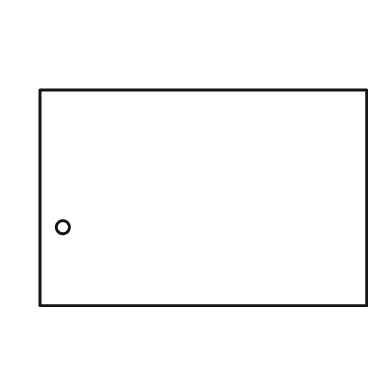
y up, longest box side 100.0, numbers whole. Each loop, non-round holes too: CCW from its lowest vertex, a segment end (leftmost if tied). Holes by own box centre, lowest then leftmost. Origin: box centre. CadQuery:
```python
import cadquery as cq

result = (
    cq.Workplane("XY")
    .moveTo(-50.0, -33.0)
    .lineTo(50.0, -33.0)
    .lineTo(50.0, 33.0)
    .lineTo(-50.0, 33.0)
    .close()
    .moveTo(-43.0, -9.0)
    .circle(2.0)
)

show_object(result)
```